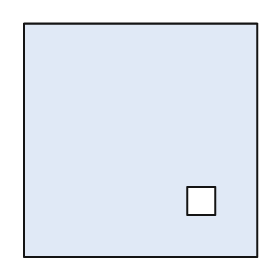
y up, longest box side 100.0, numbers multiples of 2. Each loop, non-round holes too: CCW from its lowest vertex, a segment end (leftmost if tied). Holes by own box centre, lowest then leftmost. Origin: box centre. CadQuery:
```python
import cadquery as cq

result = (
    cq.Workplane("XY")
    .moveTo(-50.0, -50.0)
    .lineTo(50.0, -50.0)
    .lineTo(50.0, 50.0)
    .lineTo(-50.0, 50.0)
    .close()
    .moveTo(20.0, -32.0)
    .lineTo(32.0, -32.0)
    .lineTo(32.0, -20.0)
    .lineTo(20.0, -20.0)
    .close()
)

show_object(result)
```